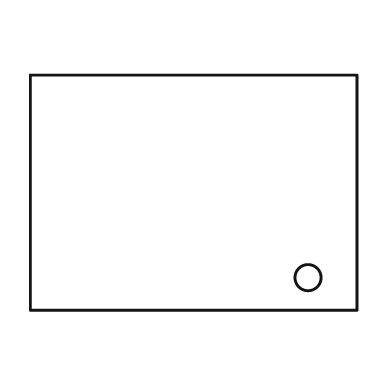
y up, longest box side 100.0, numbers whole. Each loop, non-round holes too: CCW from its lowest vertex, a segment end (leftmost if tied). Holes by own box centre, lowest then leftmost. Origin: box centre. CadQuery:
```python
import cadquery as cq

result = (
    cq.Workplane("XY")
    .moveTo(-50.0, -36.0)
    .lineTo(50.0, -36.0)
    .lineTo(50.0, 36.0)
    .lineTo(-50.0, 36.0)
    .close()
    .moveTo(35.0, -26.0)
    .circle(4.0)
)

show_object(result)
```